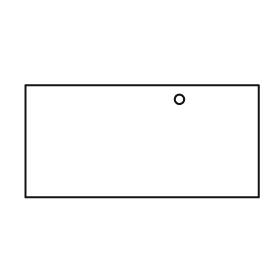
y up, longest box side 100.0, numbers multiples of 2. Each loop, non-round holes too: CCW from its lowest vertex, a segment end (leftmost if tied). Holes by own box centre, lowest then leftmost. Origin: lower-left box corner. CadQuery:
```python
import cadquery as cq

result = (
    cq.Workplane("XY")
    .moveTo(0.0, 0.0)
    .lineTo(100.0, 0.0)
    .lineTo(100.0, 48.0)
    .lineTo(0.0, 48.0)
    .close()
    .moveTo(66.0, 42.0)
    .circle(2.0)
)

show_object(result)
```